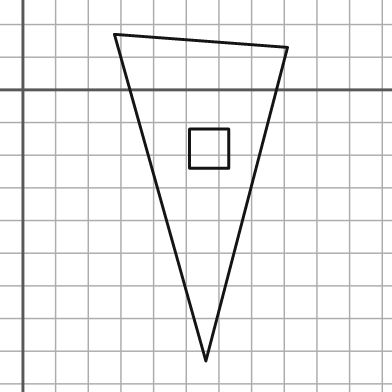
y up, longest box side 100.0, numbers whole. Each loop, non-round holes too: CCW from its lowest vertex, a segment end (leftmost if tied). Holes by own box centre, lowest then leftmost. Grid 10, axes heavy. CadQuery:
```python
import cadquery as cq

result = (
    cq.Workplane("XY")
    .moveTo(56.0, -83.0)
    .lineTo(81.0, 13.0)
    .lineTo(28.0, 17.0)
    .close()
    .moveTo(51.0, -24.0)
    .lineTo(63.0, -24.0)
    .lineTo(63.0, -12.0)
    .lineTo(51.0, -12.0)
    .close()
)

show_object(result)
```